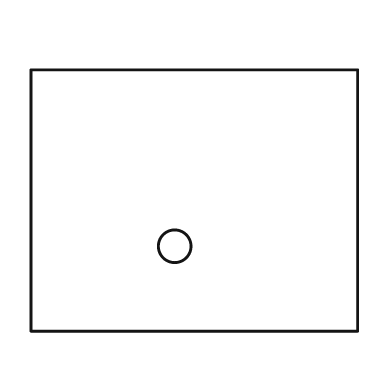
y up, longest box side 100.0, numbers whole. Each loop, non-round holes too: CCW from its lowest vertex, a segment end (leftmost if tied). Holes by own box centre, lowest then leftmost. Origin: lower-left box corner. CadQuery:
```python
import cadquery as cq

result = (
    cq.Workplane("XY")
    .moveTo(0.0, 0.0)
    .lineTo(100.0, 0.0)
    .lineTo(100.0, 80.0)
    .lineTo(0.0, 80.0)
    .close()
    .moveTo(44.0, 26.0)
    .circle(5.0)
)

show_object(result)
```